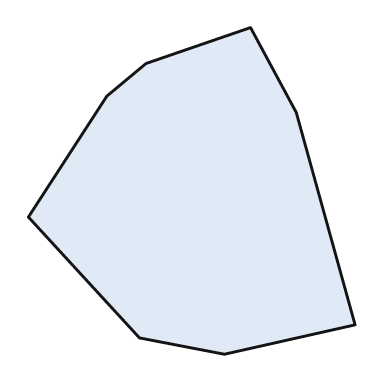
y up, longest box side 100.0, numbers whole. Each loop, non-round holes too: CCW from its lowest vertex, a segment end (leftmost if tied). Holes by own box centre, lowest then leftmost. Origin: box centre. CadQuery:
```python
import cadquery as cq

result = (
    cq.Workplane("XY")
    .moveTo(10.0, -50.0)
    .lineTo(50.0, -41.0)
    .lineTo(32.0, 24.0)
    .lineTo(18.0, 50.0)
    .lineTo(-14.0, 39.0)
    .lineTo(-26.0, 29.0)
    .lineTo(-50.0, -8.0)
    .lineTo(-16.0, -45.0)
    .close()
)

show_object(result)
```